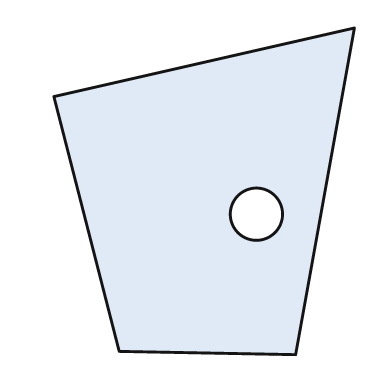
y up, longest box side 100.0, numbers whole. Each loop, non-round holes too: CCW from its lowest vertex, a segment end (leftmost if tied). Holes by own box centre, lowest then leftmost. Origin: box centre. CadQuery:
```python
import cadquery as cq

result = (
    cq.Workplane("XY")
    .moveTo(28.0, -50.0)
    .lineTo(46.0, 50.0)
    .lineTo(-46.0, 29.0)
    .lineTo(-26.0, -49.0)
    .close()
    .moveTo(16.0, -7.0)
    .circle(8.0)
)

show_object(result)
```